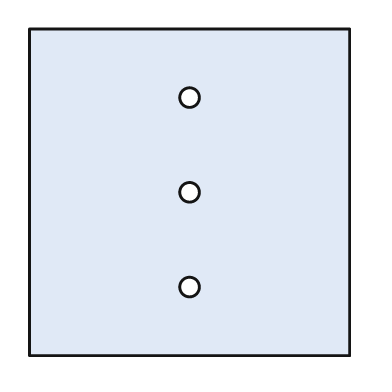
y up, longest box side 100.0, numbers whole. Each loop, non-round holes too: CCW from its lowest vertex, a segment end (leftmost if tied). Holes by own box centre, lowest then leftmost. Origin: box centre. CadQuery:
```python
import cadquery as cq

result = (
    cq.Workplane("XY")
    .moveTo(-49.0, -50.0)
    .lineTo(49.0, -50.0)
    .lineTo(49.0, 50.0)
    .lineTo(-49.0, 50.0)
    .close()
    .moveTo(0.0, -29.0)
    .circle(3.0)
    .moveTo(0.0, 0.0)
    .circle(3.0)
    .moveTo(0.0, 29.0)
    .circle(3.0)
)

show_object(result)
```